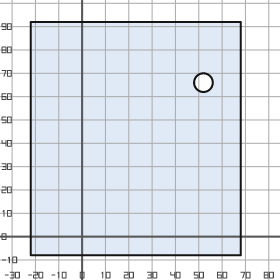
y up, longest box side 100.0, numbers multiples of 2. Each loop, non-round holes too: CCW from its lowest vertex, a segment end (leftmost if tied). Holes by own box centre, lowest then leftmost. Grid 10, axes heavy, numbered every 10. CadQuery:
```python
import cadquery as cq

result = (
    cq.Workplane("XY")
    .moveTo(-22.0, -8.0)
    .lineTo(68.0, -8.0)
    .lineTo(68.0, 92.0)
    .lineTo(-22.0, 92.0)
    .close()
    .moveTo(52.0, 66.0)
    .circle(4.0)
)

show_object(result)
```